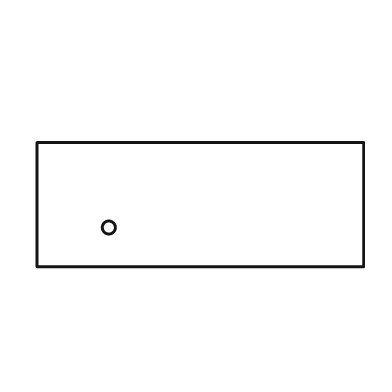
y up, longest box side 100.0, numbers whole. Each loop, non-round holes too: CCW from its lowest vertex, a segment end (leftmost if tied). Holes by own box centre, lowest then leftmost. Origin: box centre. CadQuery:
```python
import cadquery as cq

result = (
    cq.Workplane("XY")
    .moveTo(-50.0, -19.0)
    .lineTo(50.0, -19.0)
    .lineTo(50.0, 19.0)
    .lineTo(-50.0, 19.0)
    .close()
    .moveTo(-28.0, -7.0)
    .circle(2.0)
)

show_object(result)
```